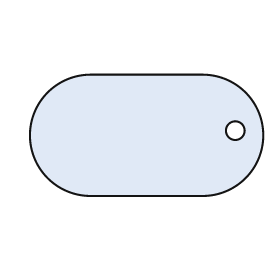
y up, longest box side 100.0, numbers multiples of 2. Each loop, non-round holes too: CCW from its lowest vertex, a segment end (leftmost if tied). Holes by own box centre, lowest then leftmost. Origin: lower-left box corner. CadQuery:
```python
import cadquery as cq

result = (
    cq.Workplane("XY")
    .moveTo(26.0, 0.0)
    .lineTo(74.0, 0.0)
    .threePointArc((100.0, 26.0), (74.0, 52.0))
    .lineTo(26.0, 52.0)
    .threePointArc((0.0, 26.0), (26.0, 0.0))
    .close()
    .moveTo(88.0, 28.0)
    .circle(4.0)
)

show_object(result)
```